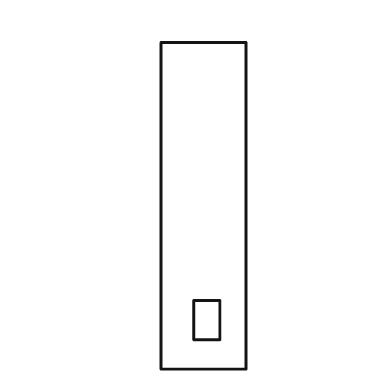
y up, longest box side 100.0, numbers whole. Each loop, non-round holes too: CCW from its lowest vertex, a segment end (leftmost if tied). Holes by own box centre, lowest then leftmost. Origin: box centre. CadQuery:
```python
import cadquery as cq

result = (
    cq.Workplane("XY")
    .moveTo(-13.0, -50.0)
    .lineTo(13.0, -50.0)
    .lineTo(13.0, 50.0)
    .lineTo(-13.0, 50.0)
    .close()
    .moveTo(-3.0, -41.0)
    .lineTo(5.0, -41.0)
    .lineTo(5.0, -29.0)
    .lineTo(-3.0, -29.0)
    .close()
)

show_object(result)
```